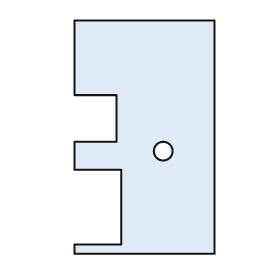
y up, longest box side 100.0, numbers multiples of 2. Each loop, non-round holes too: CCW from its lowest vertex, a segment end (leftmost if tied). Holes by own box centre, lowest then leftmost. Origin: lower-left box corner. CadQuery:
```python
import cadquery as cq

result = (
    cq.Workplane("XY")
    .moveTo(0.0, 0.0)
    .lineTo(60.0, 0.0)
    .lineTo(60.0, 100.0)
    .lineTo(0.0, 100.0)
    .lineTo(0.0, 68.0)
    .lineTo(18.0, 68.0)
    .lineTo(18.0, 48.0)
    .lineTo(0.0, 48.0)
    .lineTo(0.0, 36.0)
    .lineTo(20.0, 36.0)
    .lineTo(20.0, 4.0)
    .lineTo(0.0, 4.0)
    .close()
    .moveTo(38.0, 44.0)
    .circle(4.0)
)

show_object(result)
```